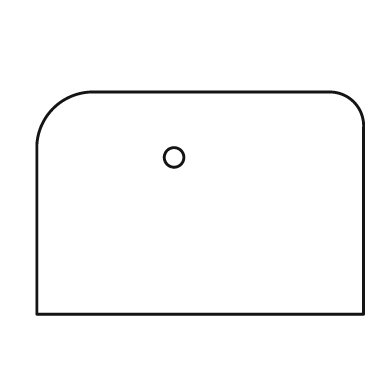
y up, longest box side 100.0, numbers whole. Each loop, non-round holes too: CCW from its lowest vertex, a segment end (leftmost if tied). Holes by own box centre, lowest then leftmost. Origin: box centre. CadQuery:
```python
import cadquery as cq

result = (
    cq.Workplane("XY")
    .moveTo(-50.0, -34.0)
    .lineTo(50.0, -34.0)
    .lineTo(50.0, 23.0)
    .threePointArc((47.0, 31.0), (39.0, 34.0))
    .lineTo(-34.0, 34.0)
    .threePointArc((-45.0, 29.0), (-50.0, 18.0))
    .close()
    .moveTo(-8.0, 14.0)
    .circle(3.0)
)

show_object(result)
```